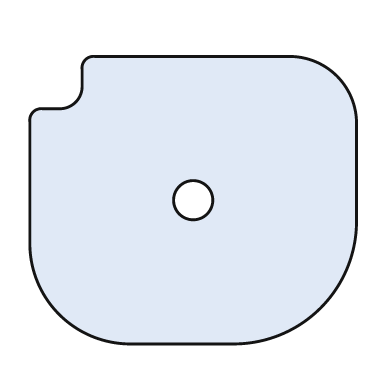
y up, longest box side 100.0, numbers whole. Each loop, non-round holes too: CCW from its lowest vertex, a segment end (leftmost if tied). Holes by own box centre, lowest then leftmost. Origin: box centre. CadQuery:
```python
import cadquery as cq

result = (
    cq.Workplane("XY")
    .moveTo(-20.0, -44.0)
    .lineTo(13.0, -44.0)
    .threePointArc((39.0, -33.0), (50.0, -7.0))
    .lineTo(50.0, 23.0)
    .threePointArc((44.0, 38.0), (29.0, 44.0))
    .lineTo(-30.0, 44.0)
    .threePointArc((-33.0, 43.0), (-34.0, 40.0))
    .lineTo(-34.0, 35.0)
    .threePointArc((-36.0, 30.0), (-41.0, 28.0))
    .lineTo(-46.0, 28.0)
    .threePointArc((-49.0, 27.0), (-50.0, 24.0))
    .lineTo(-50.0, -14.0)
    .threePointArc((-41.0, -35.0), (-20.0, -44.0))
    .close()
    .moveTo(0.0, 0.0)
    .circle(6.0)
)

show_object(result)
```